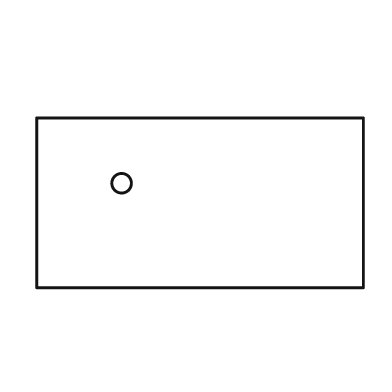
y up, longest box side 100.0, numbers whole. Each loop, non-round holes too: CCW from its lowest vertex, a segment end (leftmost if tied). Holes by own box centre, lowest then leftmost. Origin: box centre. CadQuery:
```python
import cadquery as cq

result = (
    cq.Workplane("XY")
    .moveTo(-50.0, -26.0)
    .lineTo(50.0, -26.0)
    .lineTo(50.0, 26.0)
    .lineTo(-50.0, 26.0)
    .close()
    .moveTo(-24.0, 6.0)
    .circle(3.0)
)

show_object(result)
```